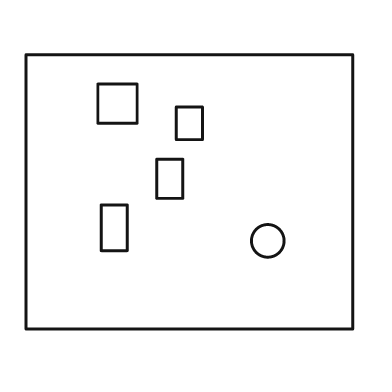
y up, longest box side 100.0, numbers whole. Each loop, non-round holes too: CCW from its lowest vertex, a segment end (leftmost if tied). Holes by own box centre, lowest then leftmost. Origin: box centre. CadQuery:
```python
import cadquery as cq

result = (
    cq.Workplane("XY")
    .moveTo(-50.0, -42.0)
    .lineTo(50.0, -42.0)
    .lineTo(50.0, 42.0)
    .lineTo(-50.0, 42.0)
    .close()
    .moveTo(24.0, -15.0)
    .circle(5.0)
    .moveTo(-27.0, -18.0)
    .lineTo(-19.0, -18.0)
    .lineTo(-19.0, -4.0)
    .lineTo(-27.0, -4.0)
    .close()
    .moveTo(-10.0, -2.0)
    .lineTo(-2.0, -2.0)
    .lineTo(-2.0, 10.0)
    .lineTo(-10.0, 10.0)
    .close()
    .moveTo(-4.0, 16.0)
    .lineTo(4.0, 16.0)
    .lineTo(4.0, 26.0)
    .lineTo(-4.0, 26.0)
    .close()
    .moveTo(-28.0, 21.0)
    .lineTo(-16.0, 21.0)
    .lineTo(-16.0, 33.0)
    .lineTo(-28.0, 33.0)
    .close()
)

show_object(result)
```